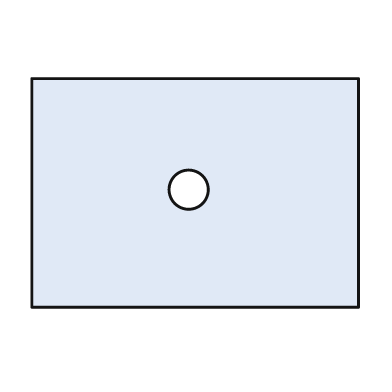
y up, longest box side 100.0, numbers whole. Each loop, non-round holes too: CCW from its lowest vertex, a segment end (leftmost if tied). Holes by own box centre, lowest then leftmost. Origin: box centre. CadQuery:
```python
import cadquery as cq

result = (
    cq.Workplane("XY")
    .moveTo(-50.0, -35.0)
    .lineTo(50.0, -35.0)
    .lineTo(50.0, 35.0)
    .lineTo(-50.0, 35.0)
    .close()
    .moveTo(-2.0, 1.0)
    .circle(6.0)
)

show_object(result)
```